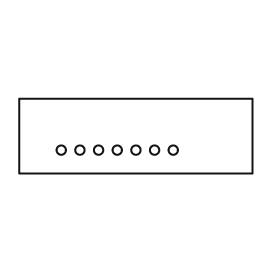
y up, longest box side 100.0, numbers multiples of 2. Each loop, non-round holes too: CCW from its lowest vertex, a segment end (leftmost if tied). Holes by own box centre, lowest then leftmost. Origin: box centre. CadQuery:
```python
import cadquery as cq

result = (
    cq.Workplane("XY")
    .moveTo(-50.0, -16.0)
    .lineTo(50.0, -16.0)
    .lineTo(50.0, 16.0)
    .lineTo(-50.0, 16.0)
    .close()
    .moveTo(-32.0, -6.0)
    .circle(2.0)
    .moveTo(-24.0, -6.0)
    .circle(2.0)
    .moveTo(-16.0, -6.0)
    .circle(2.0)
    .moveTo(-8.0, -6.0)
    .circle(2.0)
    .moveTo(0.0, -6.0)
    .circle(2.0)
    .moveTo(8.0, -6.0)
    .circle(2.0)
    .moveTo(16.0, -6.0)
    .circle(2.0)
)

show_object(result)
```